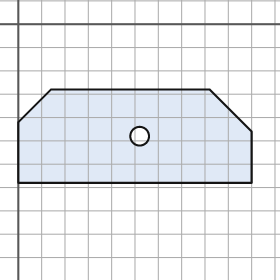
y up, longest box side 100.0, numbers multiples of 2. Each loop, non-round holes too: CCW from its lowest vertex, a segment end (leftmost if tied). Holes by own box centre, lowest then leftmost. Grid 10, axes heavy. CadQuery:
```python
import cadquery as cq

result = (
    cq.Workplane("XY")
    .moveTo(0.0, -68.0)
    .lineTo(100.0, -68.0)
    .lineTo(100.0, -46.0)
    .lineTo(82.0, -28.0)
    .lineTo(14.0, -28.0)
    .lineTo(0.0, -42.0)
    .close()
    .moveTo(52.0, -48.0)
    .circle(4.0)
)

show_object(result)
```